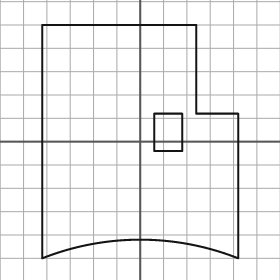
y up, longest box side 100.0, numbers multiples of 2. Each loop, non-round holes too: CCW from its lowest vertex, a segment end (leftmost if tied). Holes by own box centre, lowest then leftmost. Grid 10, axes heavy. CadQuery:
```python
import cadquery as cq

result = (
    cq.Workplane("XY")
    .moveTo(-42.0, -50.0)
    .threePointArc((0.0, -42.0), (42.0, -50.0))
    .lineTo(42.0, 12.0)
    .lineTo(24.0, 12.0)
    .lineTo(24.0, 50.0)
    .lineTo(-42.0, 50.0)
    .close()
    .moveTo(6.0, -4.0)
    .lineTo(18.0, -4.0)
    .lineTo(18.0, 12.0)
    .lineTo(6.0, 12.0)
    .close()
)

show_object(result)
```